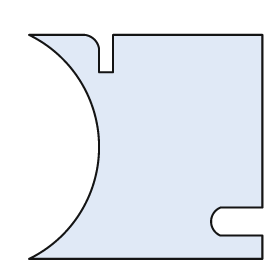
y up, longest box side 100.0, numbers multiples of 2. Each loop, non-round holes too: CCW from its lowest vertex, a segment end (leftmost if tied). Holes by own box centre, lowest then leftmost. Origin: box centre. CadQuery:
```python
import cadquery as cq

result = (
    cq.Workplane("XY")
    .moveTo(-50.0, -48.0)
    .lineTo(50.0, -48.0)
    .lineTo(50.0, -38.0)
    .lineTo(32.0, -38.0)
    .threePointArc((28.0, -32.0), (32.0, -26.0))
    .lineTo(50.0, -26.0)
    .lineTo(50.0, 48.0)
    .lineTo(-14.0, 48.0)
    .lineTo(-14.0, 32.0)
    .lineTo(-20.0, 32.0)
    .lineTo(-20.0, 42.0)
    .threePointArc((-22.0, 46.0), (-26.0, 48.0))
    .lineTo(-50.0, 48.0)
    .threePointArc((-20.0, 0.0), (-50.0, -48.0))
    .close()
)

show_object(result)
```